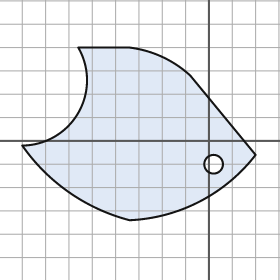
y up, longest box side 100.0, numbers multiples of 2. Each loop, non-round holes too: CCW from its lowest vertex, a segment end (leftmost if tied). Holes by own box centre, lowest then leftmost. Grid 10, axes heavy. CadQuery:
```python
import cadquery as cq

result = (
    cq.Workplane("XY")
    .moveTo(-34.0, -34.0)
    .threePointArc((-4.0, -26.0), (20.0, -6.0))
    .lineTo(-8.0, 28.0)
    .threePointArc((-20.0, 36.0), (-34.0, 40.0))
    .lineTo(-56.0, 40.0)
    .threePointArc((-56.0, 12.0), (-80.0, -2.0))
    .threePointArc((-60.0, -22.0), (-34.0, -34.0))
    .close()
    .moveTo(2.0, -10.0)
    .circle(4.0)
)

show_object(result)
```